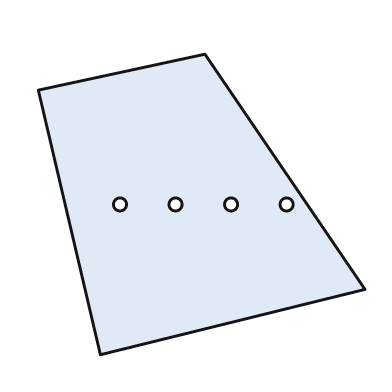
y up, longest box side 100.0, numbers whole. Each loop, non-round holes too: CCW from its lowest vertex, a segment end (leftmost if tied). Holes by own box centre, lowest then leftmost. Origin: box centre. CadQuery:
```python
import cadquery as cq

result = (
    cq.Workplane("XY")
    .moveTo(-31.0, -46.0)
    .lineTo(50.0, -26.0)
    .lineTo(1.0, 46.0)
    .lineTo(-50.0, 35.0)
    .close()
    .moveTo(-25.0, 0.0)
    .circle(2.0)
    .moveTo(-8.0, 0.0)
    .circle(2.0)
    .moveTo(9.0, 0.0)
    .circle(2.0)
    .moveTo(26.0, 0.0)
    .circle(2.0)
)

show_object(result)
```